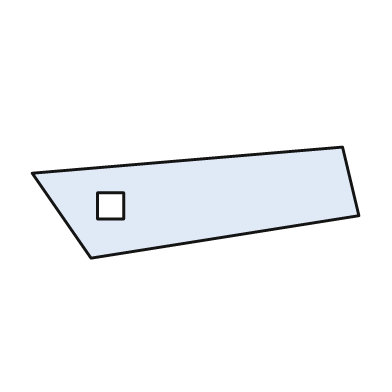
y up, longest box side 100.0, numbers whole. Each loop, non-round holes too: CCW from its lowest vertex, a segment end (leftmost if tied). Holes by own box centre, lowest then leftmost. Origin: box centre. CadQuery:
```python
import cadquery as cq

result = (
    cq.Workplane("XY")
    .moveTo(-32.0, -17.0)
    .lineTo(50.0, -4.0)
    .lineTo(45.0, 17.0)
    .lineTo(-50.0, 9.0)
    .close()
    .moveTo(-30.0, -5.0)
    .lineTo(-22.0, -5.0)
    .lineTo(-22.0, 3.0)
    .lineTo(-30.0, 3.0)
    .close()
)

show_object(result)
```